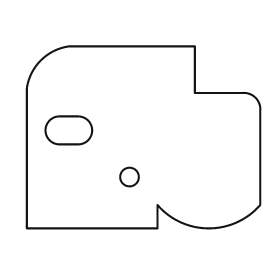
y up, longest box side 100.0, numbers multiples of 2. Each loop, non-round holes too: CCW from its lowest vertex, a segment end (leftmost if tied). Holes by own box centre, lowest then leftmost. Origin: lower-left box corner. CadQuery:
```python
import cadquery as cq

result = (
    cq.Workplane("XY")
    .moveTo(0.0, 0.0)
    .lineTo(56.0, 0.0)
    .lineTo(56.0, 10.0)
    .threePointArc((78.0, 0.0), (100.0, 10.0))
    .lineTo(100.0, 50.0)
    .threePointArc((98.0, 56.0), (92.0, 58.0))
    .lineTo(72.0, 58.0)
    .lineTo(72.0, 78.0)
    .lineTo(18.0, 78.0)
    .threePointArc((6.0, 72.0), (0.0, 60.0))
    .close()
    .moveTo(44.0, 22.0)
    .circle(4.0)
    .moveTo(14.0, 36.0)
    .lineTo(22.0, 36.0)
    .threePointArc((28.0, 42.0), (22.0, 48.0))
    .lineTo(14.0, 48.0)
    .threePointArc((8.0, 42.0), (14.0, 36.0))
    .close()
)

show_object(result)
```